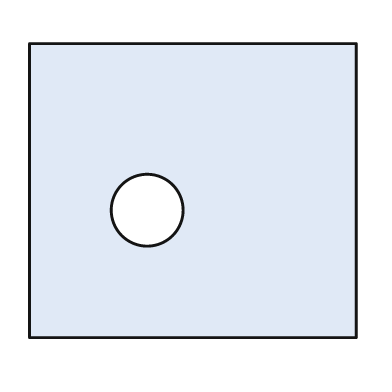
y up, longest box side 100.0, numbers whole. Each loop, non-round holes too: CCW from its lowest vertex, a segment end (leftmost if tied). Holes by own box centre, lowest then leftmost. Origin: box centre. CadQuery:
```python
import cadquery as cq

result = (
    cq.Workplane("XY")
    .moveTo(-50.0, -45.0)
    .lineTo(50.0, -45.0)
    .lineTo(50.0, 45.0)
    .lineTo(-50.0, 45.0)
    .close()
    .moveTo(-14.0, -6.0)
    .circle(11.0)
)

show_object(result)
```